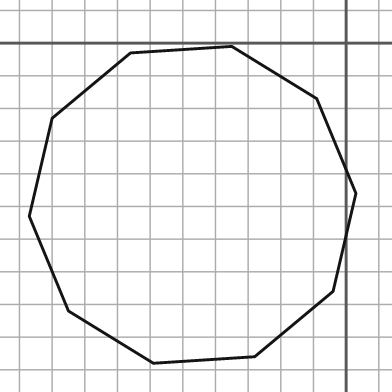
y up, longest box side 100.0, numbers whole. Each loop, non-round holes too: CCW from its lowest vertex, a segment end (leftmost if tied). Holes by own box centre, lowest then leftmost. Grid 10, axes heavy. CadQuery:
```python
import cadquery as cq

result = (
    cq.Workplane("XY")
    .moveTo(-59.0, -98.0)
    .lineTo(-28.0, -96.0)
    .lineTo(-4.0, -76.0)
    .lineTo(3.0, -46.0)
    .lineTo(-9.0, -17.0)
    .lineTo(-35.0, -1.0)
    .lineTo(-66.0, -3.0)
    .lineTo(-90.0, -23.0)
    .lineTo(-97.0, -53.0)
    .lineTo(-85.0, -82.0)
    .close()
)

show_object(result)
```